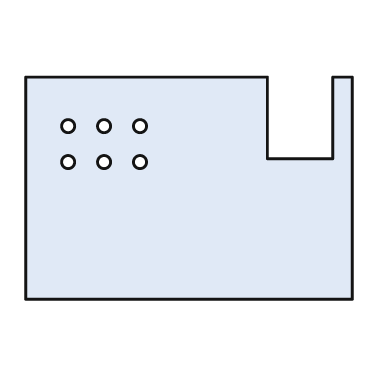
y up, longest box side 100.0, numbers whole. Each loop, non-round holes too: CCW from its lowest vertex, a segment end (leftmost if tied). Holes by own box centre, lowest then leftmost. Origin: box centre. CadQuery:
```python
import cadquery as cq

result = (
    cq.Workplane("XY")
    .moveTo(-50.0, -34.0)
    .lineTo(50.0, -34.0)
    .lineTo(50.0, 34.0)
    .lineTo(44.0, 34.0)
    .lineTo(44.0, 9.0)
    .lineTo(24.0, 9.0)
    .lineTo(24.0, 34.0)
    .lineTo(-50.0, 34.0)
    .close()
    .moveTo(-37.0, 8.0)
    .circle(2.0)
    .moveTo(-26.0, 8.0)
    .circle(2.0)
    .moveTo(-15.0, 8.0)
    .circle(2.0)
    .moveTo(-37.0, 19.0)
    .circle(2.0)
    .moveTo(-26.0, 19.0)
    .circle(2.0)
    .moveTo(-15.0, 19.0)
    .circle(2.0)
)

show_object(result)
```